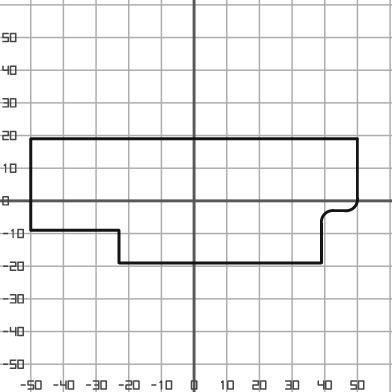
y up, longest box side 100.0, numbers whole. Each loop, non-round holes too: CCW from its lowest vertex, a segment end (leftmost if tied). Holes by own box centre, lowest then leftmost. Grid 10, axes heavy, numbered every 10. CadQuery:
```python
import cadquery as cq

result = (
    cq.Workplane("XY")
    .moveTo(-23.0, -19.0)
    .lineTo(39.0, -19.0)
    .lineTo(39.0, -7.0)
    .threePointArc((40.0, -4.0), (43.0, -3.0))
    .lineTo(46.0, -3.0)
    .threePointArc((49.0, -2.0), (50.0, 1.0))
    .lineTo(50.0, 19.0)
    .lineTo(-50.0, 19.0)
    .lineTo(-50.0, -9.0)
    .lineTo(-23.0, -9.0)
    .close()
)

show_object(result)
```